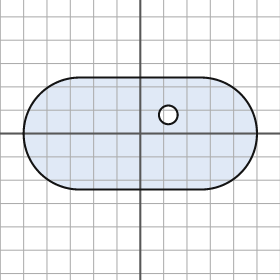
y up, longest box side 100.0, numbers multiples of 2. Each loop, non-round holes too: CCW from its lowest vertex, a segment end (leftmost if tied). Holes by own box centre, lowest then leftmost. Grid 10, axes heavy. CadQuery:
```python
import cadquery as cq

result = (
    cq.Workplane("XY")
    .moveTo(-26.0, -24.0)
    .lineTo(26.0, -24.0)
    .threePointArc((50.0, 0.0), (26.0, 24.0))
    .lineTo(-26.0, 24.0)
    .threePointArc((-50.0, 0.0), (-26.0, -24.0))
    .close()
    .moveTo(12.0, 8.0)
    .circle(4.0)
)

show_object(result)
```